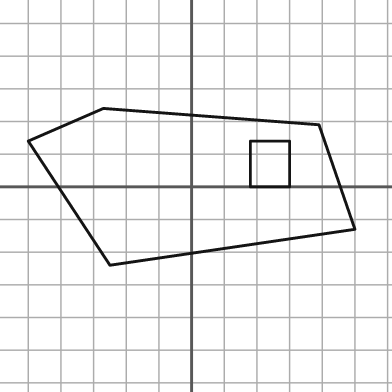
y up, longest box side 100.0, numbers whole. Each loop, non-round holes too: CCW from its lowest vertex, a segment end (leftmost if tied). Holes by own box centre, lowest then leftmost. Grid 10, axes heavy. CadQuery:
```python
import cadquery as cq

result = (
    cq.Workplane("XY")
    .moveTo(-25.0, -24.0)
    .lineTo(50.0, -13.0)
    .lineTo(39.0, 19.0)
    .lineTo(-27.0, 24.0)
    .lineTo(-50.0, 14.0)
    .close()
    .moveTo(18.0, 0.0)
    .lineTo(30.0, 0.0)
    .lineTo(30.0, 14.0)
    .lineTo(18.0, 14.0)
    .close()
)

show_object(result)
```